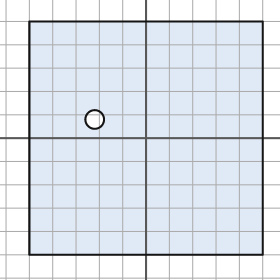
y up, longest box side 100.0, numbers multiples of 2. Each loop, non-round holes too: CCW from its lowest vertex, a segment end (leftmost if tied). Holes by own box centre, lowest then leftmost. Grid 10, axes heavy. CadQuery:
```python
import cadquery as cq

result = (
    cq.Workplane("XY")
    .moveTo(-50.0, -50.0)
    .lineTo(50.0, -50.0)
    .lineTo(50.0, 50.0)
    .lineTo(-50.0, 50.0)
    .close()
    .moveTo(-22.0, 8.0)
    .circle(4.0)
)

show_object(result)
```